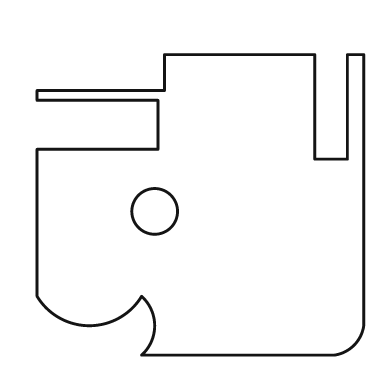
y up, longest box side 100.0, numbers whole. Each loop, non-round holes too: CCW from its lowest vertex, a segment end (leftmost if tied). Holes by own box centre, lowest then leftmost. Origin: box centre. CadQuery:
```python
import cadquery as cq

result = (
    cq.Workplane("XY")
    .moveTo(-18.0, -46.0)
    .lineTo(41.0, -46.0)
    .threePointArc((47.0, -43.0), (50.0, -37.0))
    .lineTo(50.0, 46.0)
    .lineTo(45.0, 46.0)
    .lineTo(45.0, 14.0)
    .lineTo(35.0, 14.0)
    .lineTo(35.0, 46.0)
    .lineTo(-11.0, 46.0)
    .lineTo(-11.0, 35.0)
    .lineTo(-50.0, 35.0)
    .lineTo(-50.0, 32.0)
    .lineTo(-13.0, 32.0)
    .lineTo(-13.0, 17.0)
    .lineTo(-50.0, 17.0)
    .lineTo(-50.0, -28.0)
    .threePointArc((-34.0, -37.0), (-18.0, -28.0))
    .threePointArc((-14.0, -37.0), (-18.0, -46.0))
    .close()
    .moveTo(-14.0, -2.0)
    .circle(7.0)
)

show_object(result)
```